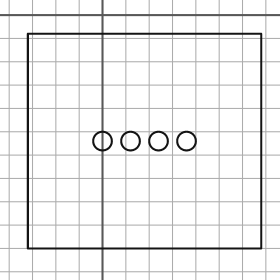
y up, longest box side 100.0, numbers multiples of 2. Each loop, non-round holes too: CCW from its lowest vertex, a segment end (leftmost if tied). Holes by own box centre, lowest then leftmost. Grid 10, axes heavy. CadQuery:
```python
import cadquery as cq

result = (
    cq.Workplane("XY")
    .moveTo(-32.0, -100.0)
    .lineTo(68.0, -100.0)
    .lineTo(68.0, -8.0)
    .lineTo(-32.0, -8.0)
    .close()
    .moveTo(0.0, -54.0)
    .circle(4.0)
    .moveTo(12.0, -54.0)
    .circle(4.0)
    .moveTo(24.0, -54.0)
    .circle(4.0)
    .moveTo(36.0, -54.0)
    .circle(4.0)
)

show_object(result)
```